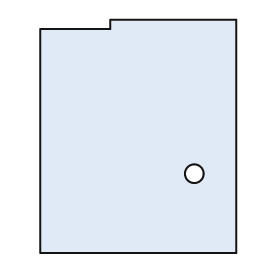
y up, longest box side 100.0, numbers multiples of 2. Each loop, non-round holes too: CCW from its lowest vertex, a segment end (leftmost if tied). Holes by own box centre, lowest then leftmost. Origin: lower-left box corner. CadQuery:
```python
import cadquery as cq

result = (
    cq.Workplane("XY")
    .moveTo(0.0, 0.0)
    .lineTo(84.0, 0.0)
    .lineTo(84.0, 100.0)
    .lineTo(30.0, 100.0)
    .lineTo(30.0, 96.0)
    .lineTo(0.0, 96.0)
    .close()
    .moveTo(66.0, 34.0)
    .circle(4.0)
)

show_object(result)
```